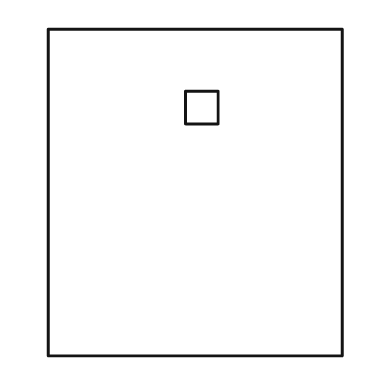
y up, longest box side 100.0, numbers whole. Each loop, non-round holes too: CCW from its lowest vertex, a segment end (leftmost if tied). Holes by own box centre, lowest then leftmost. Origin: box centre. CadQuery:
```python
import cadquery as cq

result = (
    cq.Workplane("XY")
    .moveTo(-45.0, -50.0)
    .lineTo(45.0, -50.0)
    .lineTo(45.0, 50.0)
    .lineTo(-45.0, 50.0)
    .close()
    .moveTo(-3.0, 21.0)
    .lineTo(7.0, 21.0)
    .lineTo(7.0, 31.0)
    .lineTo(-3.0, 31.0)
    .close()
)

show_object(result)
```